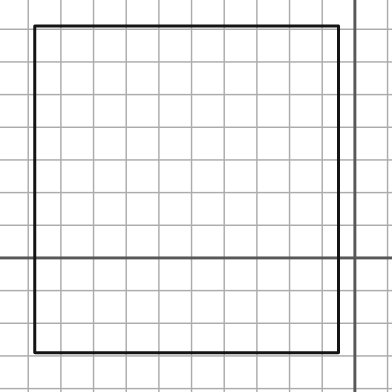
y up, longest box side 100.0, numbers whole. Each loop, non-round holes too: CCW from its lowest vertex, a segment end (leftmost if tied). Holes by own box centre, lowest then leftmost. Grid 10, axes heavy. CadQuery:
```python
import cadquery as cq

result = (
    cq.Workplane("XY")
    .moveTo(-98.0, -29.0)
    .lineTo(-5.0, -29.0)
    .lineTo(-5.0, 71.0)
    .lineTo(-98.0, 71.0)
    .close()
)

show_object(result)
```